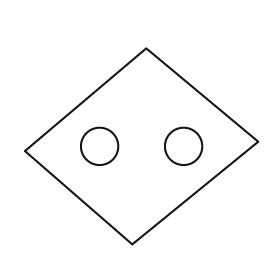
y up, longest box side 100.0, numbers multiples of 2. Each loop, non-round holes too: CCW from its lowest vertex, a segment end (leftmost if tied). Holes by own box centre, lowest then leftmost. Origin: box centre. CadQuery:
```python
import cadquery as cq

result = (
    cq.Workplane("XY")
    .moveTo(-4.0, -42.0)
    .lineTo(50.0, 2.0)
    .lineTo(2.0, 42.0)
    .lineTo(-50.0, -2.0)
    .close()
    .moveTo(-18.0, 0.0)
    .circle(8.0)
    .moveTo(18.0, 0.0)
    .circle(8.0)
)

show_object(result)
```